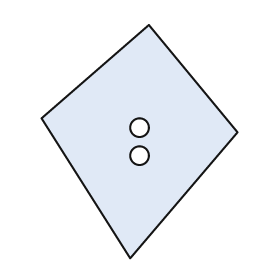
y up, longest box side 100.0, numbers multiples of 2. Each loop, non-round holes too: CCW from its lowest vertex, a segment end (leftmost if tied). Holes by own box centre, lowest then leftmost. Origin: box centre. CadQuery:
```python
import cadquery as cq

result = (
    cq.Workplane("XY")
    .moveTo(-4.0, -50.0)
    .lineTo(42.0, 4.0)
    .lineTo(4.0, 50.0)
    .lineTo(-42.0, 10.0)
    .close()
    .moveTo(0.0, -6.0)
    .circle(4.0)
    .moveTo(0.0, 6.0)
    .circle(4.0)
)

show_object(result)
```